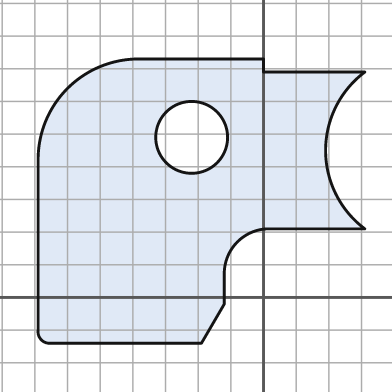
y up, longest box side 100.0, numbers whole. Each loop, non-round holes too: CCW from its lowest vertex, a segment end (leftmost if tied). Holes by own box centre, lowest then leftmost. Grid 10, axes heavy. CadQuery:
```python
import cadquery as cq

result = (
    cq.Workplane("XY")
    .moveTo(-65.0, -14.0)
    .lineTo(-19.0, -14.0)
    .lineTo(-12.0, -2.0)
    .lineTo(-12.0, 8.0)
    .threePointArc((-8.0, 17.0), (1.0, 21.0))
    .lineTo(31.0, 21.0)
    .threePointArc((19.0, 45.0), (31.0, 69.0))
    .lineTo(0.0, 69.0)
    .lineTo(0.0, 73.0)
    .lineTo(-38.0, 73.0)
    .threePointArc((-60.0, 64.0), (-69.0, 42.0))
    .lineTo(-69.0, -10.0)
    .threePointArc((-68.0, -13.0), (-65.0, -14.0))
    .close()
    .moveTo(-22.0, 49.0)
    .circle(11.0)
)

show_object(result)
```